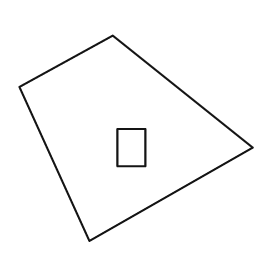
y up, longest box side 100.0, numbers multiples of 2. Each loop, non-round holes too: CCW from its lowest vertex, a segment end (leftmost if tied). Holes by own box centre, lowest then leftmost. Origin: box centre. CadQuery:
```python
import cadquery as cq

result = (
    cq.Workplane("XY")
    .moveTo(-20.0, -44.0)
    .lineTo(50.0, -4.0)
    .lineTo(-10.0, 44.0)
    .lineTo(-50.0, 22.0)
    .close()
    .moveTo(-8.0, -12.0)
    .lineTo(4.0, -12.0)
    .lineTo(4.0, 4.0)
    .lineTo(-8.0, 4.0)
    .close()
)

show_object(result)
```